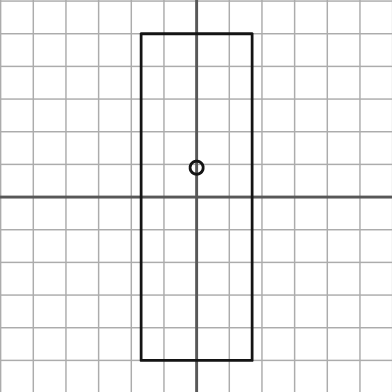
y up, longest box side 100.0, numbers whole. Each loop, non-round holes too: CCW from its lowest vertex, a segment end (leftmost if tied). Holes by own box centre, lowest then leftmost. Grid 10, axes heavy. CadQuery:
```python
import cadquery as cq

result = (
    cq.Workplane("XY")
    .moveTo(-17.0, -50.0)
    .lineTo(17.0, -50.0)
    .lineTo(17.0, 50.0)
    .lineTo(-17.0, 50.0)
    .close()
    .moveTo(0.0, 9.0)
    .circle(2.0)
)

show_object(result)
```